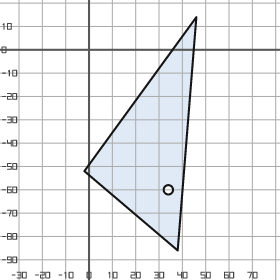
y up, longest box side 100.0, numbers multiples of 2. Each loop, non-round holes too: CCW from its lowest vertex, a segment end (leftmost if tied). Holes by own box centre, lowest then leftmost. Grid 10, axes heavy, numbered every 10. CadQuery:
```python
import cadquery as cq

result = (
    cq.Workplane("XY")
    .moveTo(38.0, -86.0)
    .lineTo(46.0, 14.0)
    .lineTo(-2.0, -52.0)
    .close()
    .moveTo(34.0, -60.0)
    .circle(2.0)
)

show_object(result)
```